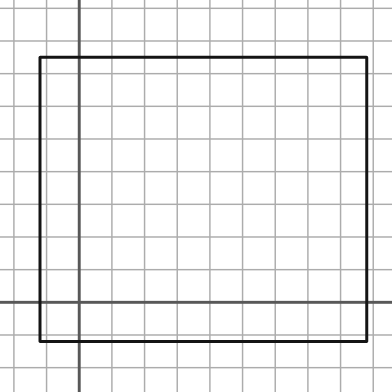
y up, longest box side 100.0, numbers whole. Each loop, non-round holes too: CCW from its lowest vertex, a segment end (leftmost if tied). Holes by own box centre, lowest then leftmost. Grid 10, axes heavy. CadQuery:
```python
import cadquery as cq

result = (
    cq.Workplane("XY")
    .moveTo(-12.0, -12.0)
    .lineTo(88.0, -12.0)
    .lineTo(88.0, 75.0)
    .lineTo(-12.0, 75.0)
    .close()
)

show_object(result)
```